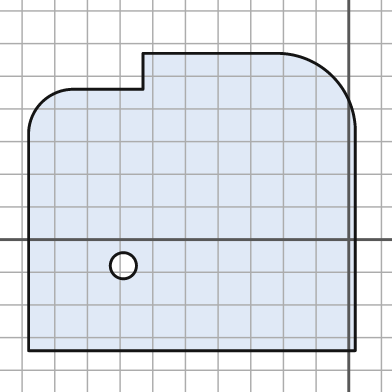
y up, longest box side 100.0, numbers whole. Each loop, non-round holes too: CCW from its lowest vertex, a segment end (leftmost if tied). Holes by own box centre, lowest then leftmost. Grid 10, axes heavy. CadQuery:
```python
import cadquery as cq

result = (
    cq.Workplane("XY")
    .moveTo(-98.0, -34.0)
    .lineTo(2.0, -34.0)
    .lineTo(2.0, 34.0)
    .threePointArc((-5.0, 50.0), (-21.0, 57.0))
    .lineTo(-63.0, 57.0)
    .lineTo(-63.0, 46.0)
    .lineTo(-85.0, 46.0)
    .threePointArc((-94.0, 42.0), (-98.0, 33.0))
    .close()
    .moveTo(-69.0, -8.0)
    .circle(4.0)
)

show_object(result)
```